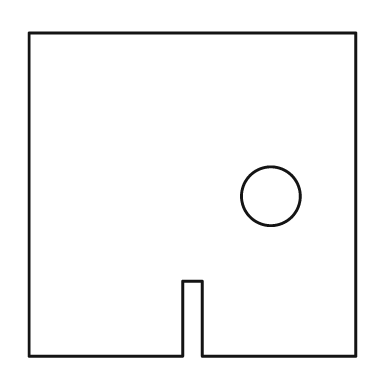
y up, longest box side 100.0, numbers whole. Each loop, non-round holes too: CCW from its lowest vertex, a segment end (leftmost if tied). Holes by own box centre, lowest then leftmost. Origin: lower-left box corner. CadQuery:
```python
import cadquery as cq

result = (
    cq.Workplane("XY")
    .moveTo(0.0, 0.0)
    .lineTo(47.0, 0.0)
    .lineTo(47.0, 23.0)
    .lineTo(53.0, 23.0)
    .lineTo(53.0, 0.0)
    .lineTo(100.0, 0.0)
    .lineTo(100.0, 99.0)
    .lineTo(0.0, 99.0)
    .close()
    .moveTo(74.0, 49.0)
    .circle(9.0)
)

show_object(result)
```